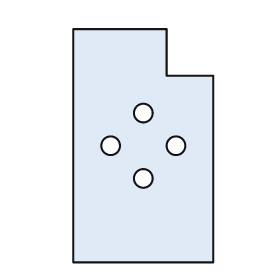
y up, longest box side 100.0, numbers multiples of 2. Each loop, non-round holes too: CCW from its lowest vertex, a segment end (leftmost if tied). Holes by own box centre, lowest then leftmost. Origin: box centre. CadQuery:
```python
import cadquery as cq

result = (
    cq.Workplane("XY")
    .moveTo(-30.0, -50.0)
    .lineTo(30.0, -50.0)
    .lineTo(30.0, 30.0)
    .lineTo(10.0, 30.0)
    .lineTo(10.0, 50.0)
    .lineTo(-30.0, 50.0)
    .close()
    .moveTo(0.0, -14.0)
    .circle(4.0)
    .moveTo(-14.0, 0.0)
    .circle(4.0)
    .moveTo(14.0, 0.0)
    .circle(4.0)
    .moveTo(0.0, 14.0)
    .circle(4.0)
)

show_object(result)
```